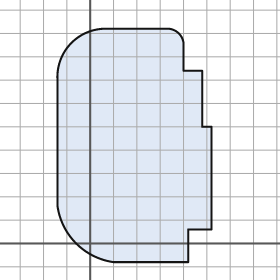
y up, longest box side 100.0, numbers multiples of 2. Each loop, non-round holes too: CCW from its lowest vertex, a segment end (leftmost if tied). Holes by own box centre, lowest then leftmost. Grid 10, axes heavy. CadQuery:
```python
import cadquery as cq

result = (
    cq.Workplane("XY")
    .moveTo(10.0, -8.0)
    .lineTo(42.0, -8.0)
    .lineTo(42.0, 6.0)
    .lineTo(52.0, 6.0)
    .lineTo(52.0, 50.0)
    .lineTo(48.0, 50.0)
    .lineTo(48.0, 74.0)
    .lineTo(40.0, 74.0)
    .lineTo(40.0, 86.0)
    .threePointArc((38.0, 90.0), (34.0, 92.0))
    .lineTo(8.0, 92.0)
    .threePointArc((-8.0, 86.0), (-14.0, 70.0))
    .lineTo(-14.0, 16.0)
    .threePointArc((-6.0, 0.0), (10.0, -8.0))
    .close()
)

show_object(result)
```